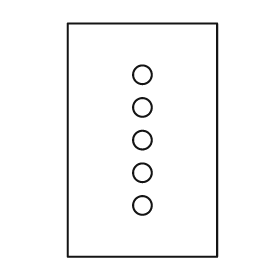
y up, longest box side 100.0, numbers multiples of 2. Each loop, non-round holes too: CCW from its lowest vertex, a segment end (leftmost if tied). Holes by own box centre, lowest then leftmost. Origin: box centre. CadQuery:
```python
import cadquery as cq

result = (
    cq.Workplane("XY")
    .moveTo(-32.0, -50.0)
    .lineTo(32.0, -50.0)
    .lineTo(32.0, 50.0)
    .lineTo(-32.0, 50.0)
    .close()
    .moveTo(0.0, -28.0)
    .circle(4.0)
    .moveTo(0.0, -14.0)
    .circle(4.0)
    .moveTo(0.0, 0.0)
    .circle(4.0)
    .moveTo(0.0, 14.0)
    .circle(4.0)
    .moveTo(0.0, 28.0)
    .circle(4.0)
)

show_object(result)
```